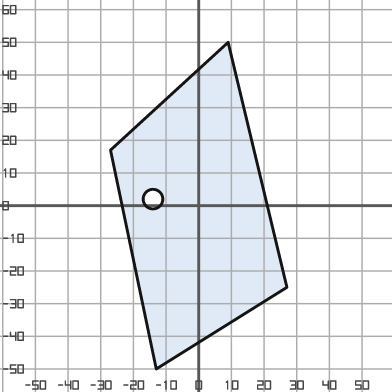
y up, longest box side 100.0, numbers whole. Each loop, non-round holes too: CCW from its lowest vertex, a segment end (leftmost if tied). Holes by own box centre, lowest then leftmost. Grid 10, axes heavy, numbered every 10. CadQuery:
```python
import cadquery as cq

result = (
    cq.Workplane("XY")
    .moveTo(-13.0, -50.0)
    .lineTo(27.0, -25.0)
    .lineTo(9.0, 50.0)
    .lineTo(-27.0, 17.0)
    .close()
    .moveTo(-14.0, 2.0)
    .circle(3.0)
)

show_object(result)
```